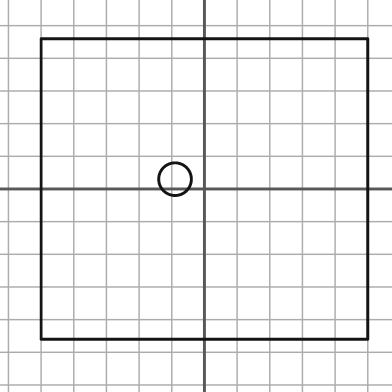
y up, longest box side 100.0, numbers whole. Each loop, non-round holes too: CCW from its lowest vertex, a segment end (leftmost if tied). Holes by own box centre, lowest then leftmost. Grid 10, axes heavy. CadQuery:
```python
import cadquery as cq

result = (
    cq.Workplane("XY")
    .moveTo(-50.0, -46.0)
    .lineTo(50.0, -46.0)
    .lineTo(50.0, 46.0)
    .lineTo(-50.0, 46.0)
    .close()
    .moveTo(-9.0, 3.0)
    .circle(5.0)
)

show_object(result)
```